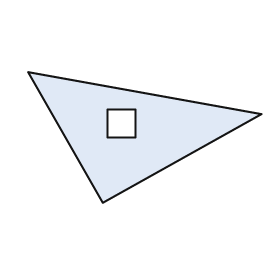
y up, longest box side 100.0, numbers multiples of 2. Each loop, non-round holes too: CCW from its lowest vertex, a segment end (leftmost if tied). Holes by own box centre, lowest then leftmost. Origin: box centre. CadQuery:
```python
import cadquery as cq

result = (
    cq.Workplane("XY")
    .moveTo(-18.0, -28.0)
    .lineTo(50.0, 10.0)
    .lineTo(-50.0, 28.0)
    .close()
    .moveTo(-16.0, 0.0)
    .lineTo(-4.0, 0.0)
    .lineTo(-4.0, 12.0)
    .lineTo(-16.0, 12.0)
    .close()
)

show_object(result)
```